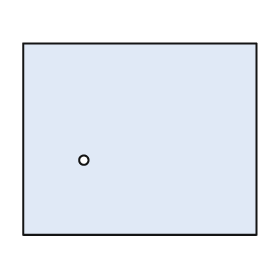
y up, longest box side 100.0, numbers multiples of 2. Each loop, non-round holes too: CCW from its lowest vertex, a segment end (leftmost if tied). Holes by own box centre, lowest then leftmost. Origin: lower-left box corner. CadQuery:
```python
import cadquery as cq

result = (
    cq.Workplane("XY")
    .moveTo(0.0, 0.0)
    .lineTo(100.0, 0.0)
    .lineTo(100.0, 82.0)
    .lineTo(0.0, 82.0)
    .close()
    .moveTo(26.0, 32.0)
    .circle(2.0)
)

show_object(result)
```